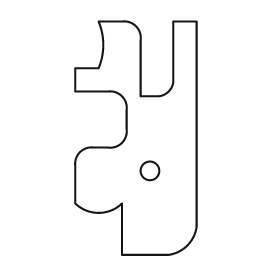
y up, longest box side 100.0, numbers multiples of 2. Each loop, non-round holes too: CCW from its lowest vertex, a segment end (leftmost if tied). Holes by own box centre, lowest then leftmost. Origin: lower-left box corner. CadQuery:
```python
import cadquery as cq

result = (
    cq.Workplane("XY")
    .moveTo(20.0, 0.0)
    .lineTo(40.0, 0.0)
    .threePointArc((48.0, 4.0), (52.0, 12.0))
    .lineTo(52.0, 100.0)
    .lineTo(42.0, 100.0)
    .lineTo(42.0, 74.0)
    .threePointArc((40.0, 70.0), (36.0, 68.0))
    .lineTo(28.0, 68.0)
    .lineTo(28.0, 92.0)
    .threePointArc((26.0, 98.0), (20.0, 100.0))
    .lineTo(10.0, 100.0)
    .threePointArc((12.0, 90.0), (10.0, 80.0))
    .lineTo(0.0, 80.0)
    .lineTo(0.0, 70.0)
    .lineTo(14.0, 70.0)
    .threePointArc((20.0, 68.0), (22.0, 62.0))
    .lineTo(22.0, 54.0)
    .threePointArc((20.0, 48.0), (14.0, 46.0))
    .lineTo(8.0, 46.0)
    .threePointArc((2.0, 44.0), (0.0, 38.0))
    .lineTo(0.0, 22.0)
    .threePointArc((10.0, 18.0), (20.0, 22.0))
    .close()
    .moveTo(32.0, 36.0)
    .circle(4.0)
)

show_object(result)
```